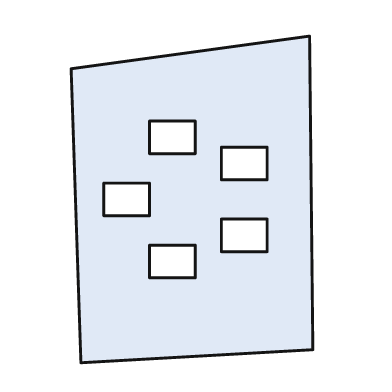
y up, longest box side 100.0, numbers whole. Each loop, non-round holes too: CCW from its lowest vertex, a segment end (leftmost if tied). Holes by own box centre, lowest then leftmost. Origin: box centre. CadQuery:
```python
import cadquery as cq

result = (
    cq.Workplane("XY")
    .moveTo(-34.0, -50.0)
    .lineTo(37.0, -46.0)
    .lineTo(36.0, 50.0)
    .lineTo(-37.0, 40.0)
    .close()
    .moveTo(-13.0, -24.0)
    .lineTo(1.0, -24.0)
    .lineTo(1.0, -14.0)
    .lineTo(-13.0, -14.0)
    .close()
    .moveTo(9.0, -16.0)
    .lineTo(23.0, -16.0)
    .lineTo(23.0, -6.0)
    .lineTo(9.0, -6.0)
    .close()
    .moveTo(-27.0, -5.0)
    .lineTo(-13.0, -5.0)
    .lineTo(-13.0, 5.0)
    .lineTo(-27.0, 5.0)
    .close()
    .moveTo(9.0, 6.0)
    .lineTo(23.0, 6.0)
    .lineTo(23.0, 16.0)
    .lineTo(9.0, 16.0)
    .close()
    .moveTo(-13.0, 14.0)
    .lineTo(1.0, 14.0)
    .lineTo(1.0, 24.0)
    .lineTo(-13.0, 24.0)
    .close()
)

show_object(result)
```